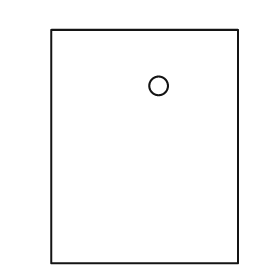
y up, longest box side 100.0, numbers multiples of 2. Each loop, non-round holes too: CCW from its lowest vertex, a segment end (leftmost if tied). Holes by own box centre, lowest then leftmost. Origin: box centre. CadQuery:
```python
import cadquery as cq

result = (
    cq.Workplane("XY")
    .moveTo(-40.0, -50.0)
    .lineTo(40.0, -50.0)
    .lineTo(40.0, 50.0)
    .lineTo(-40.0, 50.0)
    .close()
    .moveTo(6.0, 26.0)
    .circle(4.0)
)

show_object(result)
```